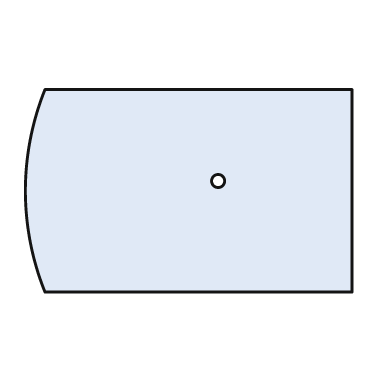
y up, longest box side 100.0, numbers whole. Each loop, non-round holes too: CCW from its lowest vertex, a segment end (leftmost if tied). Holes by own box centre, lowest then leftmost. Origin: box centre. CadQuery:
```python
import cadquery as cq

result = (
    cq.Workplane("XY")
    .moveTo(-44.0, -31.0)
    .lineTo(50.0, -31.0)
    .lineTo(50.0, 31.0)
    .lineTo(-44.0, 31.0)
    .threePointArc((-50.0, 0.0), (-44.0, -31.0))
    .close()
    .moveTo(9.0, 3.0)
    .circle(2.0)
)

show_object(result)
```